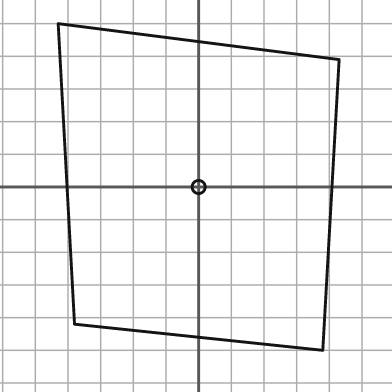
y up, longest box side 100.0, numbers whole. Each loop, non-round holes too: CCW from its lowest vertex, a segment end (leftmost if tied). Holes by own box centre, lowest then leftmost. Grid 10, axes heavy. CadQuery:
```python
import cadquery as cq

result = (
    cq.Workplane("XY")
    .moveTo(38.0, -50.0)
    .lineTo(43.0, 39.0)
    .lineTo(-43.0, 50.0)
    .lineTo(-38.0, -42.0)
    .close()
    .moveTo(0.0, 0.0)
    .circle(2.0)
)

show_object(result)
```